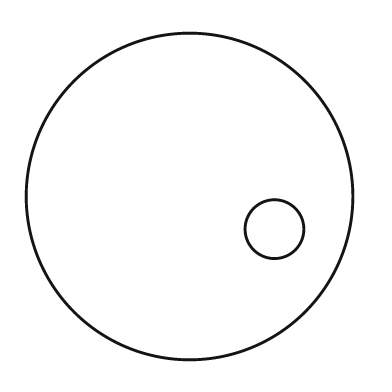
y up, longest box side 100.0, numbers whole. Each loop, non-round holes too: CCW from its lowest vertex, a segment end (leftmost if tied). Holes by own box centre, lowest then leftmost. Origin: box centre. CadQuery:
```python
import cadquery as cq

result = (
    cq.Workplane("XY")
    .moveTo(0.0, 0.0)
    .circle(50.0)
    .moveTo(26.0, -10.0)
    .circle(9.0)
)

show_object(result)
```